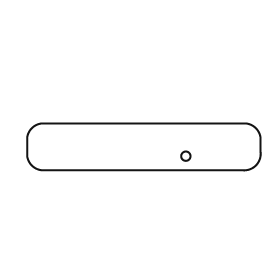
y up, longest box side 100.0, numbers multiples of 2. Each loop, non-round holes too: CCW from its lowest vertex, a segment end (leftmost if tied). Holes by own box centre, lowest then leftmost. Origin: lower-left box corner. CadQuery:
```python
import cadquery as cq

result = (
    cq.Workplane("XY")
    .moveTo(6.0, 0.0)
    .lineTo(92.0, 0.0)
    .threePointArc((98.0, 2.0), (100.0, 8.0))
    .lineTo(100.0, 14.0)
    .threePointArc((98.0, 18.0), (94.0, 20.0))
    .lineTo(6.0, 20.0)
    .threePointArc((2.0, 18.0), (0.0, 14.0))
    .lineTo(0.0, 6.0)
    .threePointArc((2.0, 2.0), (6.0, 0.0))
    .close()
    .moveTo(68.0, 6.0)
    .circle(2.0)
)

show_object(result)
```